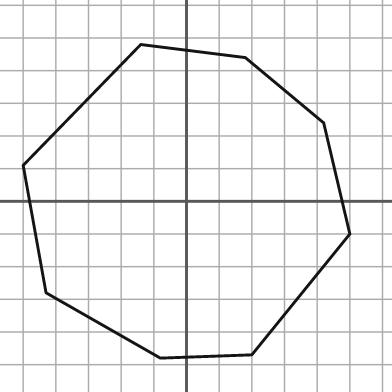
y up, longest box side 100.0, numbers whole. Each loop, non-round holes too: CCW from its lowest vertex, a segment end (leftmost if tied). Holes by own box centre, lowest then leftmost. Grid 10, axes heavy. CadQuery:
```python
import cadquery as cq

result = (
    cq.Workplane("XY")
    .moveTo(-8.0, -48.0)
    .lineTo(20.0, -47.0)
    .lineTo(50.0, -10.0)
    .lineTo(42.0, 24.0)
    .lineTo(18.0, 44.0)
    .lineTo(-14.0, 48.0)
    .lineTo(-50.0, 11.0)
    .lineTo(-43.0, -28.0)
    .close()
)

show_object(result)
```